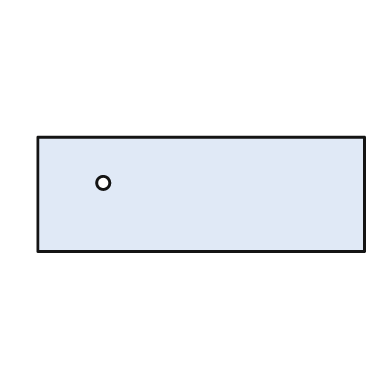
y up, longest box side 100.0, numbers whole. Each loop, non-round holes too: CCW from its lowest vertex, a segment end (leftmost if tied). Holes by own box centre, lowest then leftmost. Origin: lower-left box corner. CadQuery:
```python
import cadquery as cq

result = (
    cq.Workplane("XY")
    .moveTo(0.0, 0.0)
    .lineTo(100.0, 0.0)
    .lineTo(100.0, 35.0)
    .lineTo(0.0, 35.0)
    .close()
    .moveTo(20.0, 21.0)
    .circle(2.0)
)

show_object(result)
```